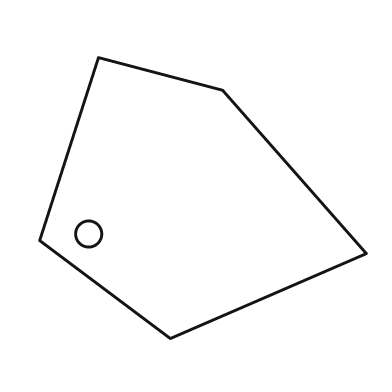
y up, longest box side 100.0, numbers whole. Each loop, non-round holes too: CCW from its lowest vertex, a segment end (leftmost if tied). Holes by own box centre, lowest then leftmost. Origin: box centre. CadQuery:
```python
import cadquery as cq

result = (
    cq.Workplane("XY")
    .moveTo(-10.0, -43.0)
    .lineTo(50.0, -17.0)
    .lineTo(6.0, 33.0)
    .lineTo(-32.0, 43.0)
    .lineTo(-50.0, -13.0)
    .close()
    .moveTo(-35.0, -11.0)
    .circle(4.0)
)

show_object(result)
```